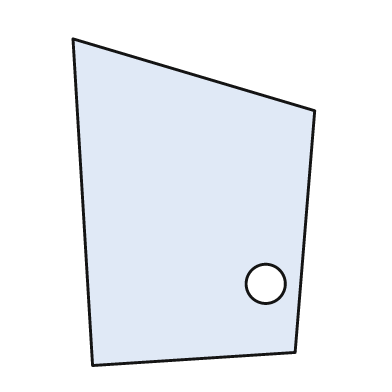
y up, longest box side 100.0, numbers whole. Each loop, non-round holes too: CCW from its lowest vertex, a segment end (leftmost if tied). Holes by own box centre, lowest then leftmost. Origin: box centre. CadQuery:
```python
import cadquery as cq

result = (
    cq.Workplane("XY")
    .moveTo(-31.0, -50.0)
    .lineTo(31.0, -46.0)
    .lineTo(37.0, 28.0)
    .lineTo(-37.0, 50.0)
    .close()
    .moveTo(22.0, -25.0)
    .circle(6.0)
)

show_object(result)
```